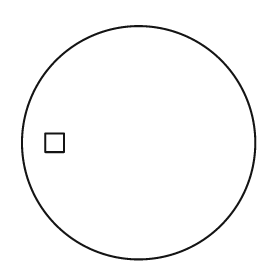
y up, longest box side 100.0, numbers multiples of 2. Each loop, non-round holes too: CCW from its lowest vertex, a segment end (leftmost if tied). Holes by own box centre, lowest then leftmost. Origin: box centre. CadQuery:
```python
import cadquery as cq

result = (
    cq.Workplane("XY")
    .moveTo(0.0, 0.0)
    .circle(50.0)
    .moveTo(-40.0, -4.0)
    .lineTo(-32.0, -4.0)
    .lineTo(-32.0, 4.0)
    .lineTo(-40.0, 4.0)
    .close()
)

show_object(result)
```